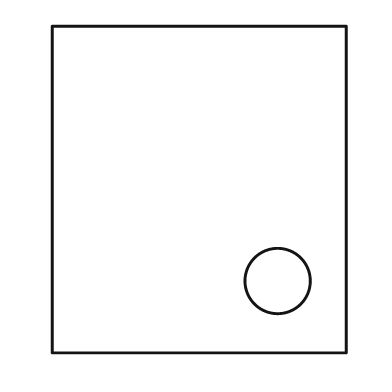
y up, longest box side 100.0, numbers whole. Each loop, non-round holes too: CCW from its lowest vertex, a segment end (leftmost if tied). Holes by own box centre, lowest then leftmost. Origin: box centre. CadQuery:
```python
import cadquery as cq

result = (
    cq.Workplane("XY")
    .moveTo(-45.0, -50.0)
    .lineTo(45.0, -50.0)
    .lineTo(45.0, 50.0)
    .lineTo(-45.0, 50.0)
    .close()
    .moveTo(24.0, -28.0)
    .circle(10.0)
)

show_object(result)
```